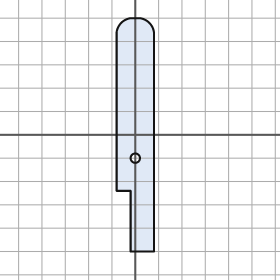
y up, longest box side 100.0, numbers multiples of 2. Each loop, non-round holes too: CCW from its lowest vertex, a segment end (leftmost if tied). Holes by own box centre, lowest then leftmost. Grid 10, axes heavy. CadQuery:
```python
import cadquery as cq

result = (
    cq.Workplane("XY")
    .moveTo(-2.0, -50.0)
    .lineTo(8.0, -50.0)
    .lineTo(8.0, 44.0)
    .threePointArc((6.0, 48.0), (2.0, 50.0))
    .lineTo(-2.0, 50.0)
    .threePointArc((-6.0, 48.0), (-8.0, 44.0))
    .lineTo(-8.0, -24.0)
    .lineTo(-2.0, -24.0)
    .close()
    .moveTo(0.0, -10.0)
    .circle(2.0)
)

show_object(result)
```